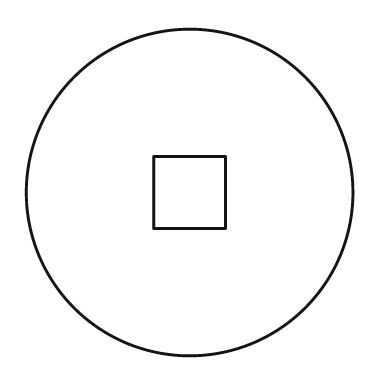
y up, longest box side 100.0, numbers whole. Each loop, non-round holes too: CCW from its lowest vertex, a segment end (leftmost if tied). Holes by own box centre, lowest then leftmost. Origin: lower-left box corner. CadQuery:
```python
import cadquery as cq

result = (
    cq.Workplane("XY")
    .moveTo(50.0, 50.0)
    .circle(50.0)
    .moveTo(39.0, 39.0)
    .lineTo(61.0, 39.0)
    .lineTo(61.0, 61.0)
    .lineTo(39.0, 61.0)
    .close()
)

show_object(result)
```